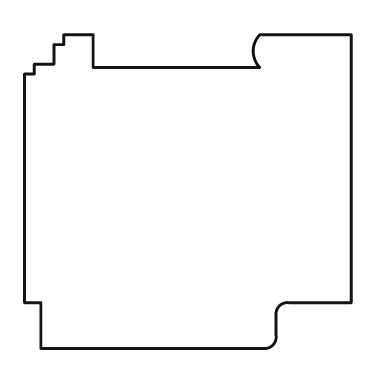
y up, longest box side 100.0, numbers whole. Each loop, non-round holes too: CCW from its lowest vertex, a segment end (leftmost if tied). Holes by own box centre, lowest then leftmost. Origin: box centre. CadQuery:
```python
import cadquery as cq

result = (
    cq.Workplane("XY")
    .moveTo(-45.0, -48.0)
    .lineTo(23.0, -48.0)
    .threePointArc((26.0, -47.0), (27.0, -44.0))
    .lineTo(27.0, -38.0)
    .threePointArc((28.0, -35.0), (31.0, -34.0))
    .lineTo(50.0, -34.0)
    .lineTo(50.0, 48.0)
    .lineTo(22.0, 48.0)
    .threePointArc((20.0, 43.0), (22.0, 38.0))
    .lineTo(-29.0, 38.0)
    .lineTo(-29.0, 48.0)
    .lineTo(-38.0, 48.0)
    .lineTo(-38.0, 45.0)
    .lineTo(-41.0, 45.0)
    .lineTo(-41.0, 39.0)
    .lineTo(-47.0, 39.0)
    .lineTo(-47.0, 36.0)
    .lineTo(-50.0, 36.0)
    .lineTo(-50.0, -34.0)
    .lineTo(-45.0, -34.0)
    .close()
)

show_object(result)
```